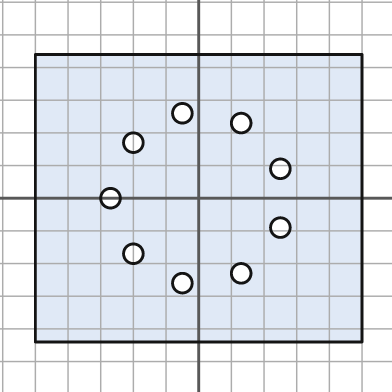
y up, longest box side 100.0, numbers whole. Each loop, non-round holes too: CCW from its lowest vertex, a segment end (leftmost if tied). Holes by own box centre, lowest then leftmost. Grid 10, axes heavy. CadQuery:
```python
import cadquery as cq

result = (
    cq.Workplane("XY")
    .moveTo(-50.0, -44.0)
    .lineTo(50.0, -44.0)
    .lineTo(50.0, 44.0)
    .lineTo(-50.0, 44.0)
    .close()
    .moveTo(-5.0, -26.0)
    .circle(3.0)
    .moveTo(13.0, -23.0)
    .circle(3.0)
    .moveTo(-20.0, -17.0)
    .circle(3.0)
    .moveTo(25.0, -9.0)
    .circle(3.0)
    .moveTo(-27.0, 0.0)
    .circle(3.0)
    .moveTo(25.0, 9.0)
    .circle(3.0)
    .moveTo(-20.0, 17.0)
    .circle(3.0)
    .moveTo(13.0, 23.0)
    .circle(3.0)
    .moveTo(-5.0, 26.0)
    .circle(3.0)
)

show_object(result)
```